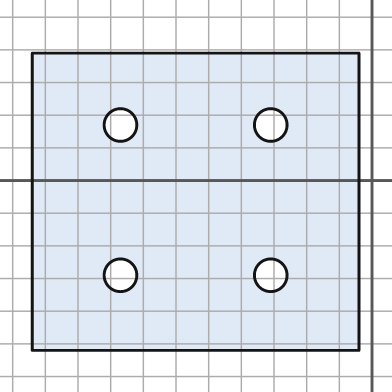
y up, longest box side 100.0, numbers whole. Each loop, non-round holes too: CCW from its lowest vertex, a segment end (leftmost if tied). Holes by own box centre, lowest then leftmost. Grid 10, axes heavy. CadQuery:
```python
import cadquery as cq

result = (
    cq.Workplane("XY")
    .moveTo(-104.0, -52.0)
    .lineTo(-4.0, -52.0)
    .lineTo(-4.0, 39.0)
    .lineTo(-104.0, 39.0)
    .close()
    .moveTo(-77.0, -29.0)
    .circle(5.0)
    .moveTo(-31.0, -29.0)
    .circle(5.0)
    .moveTo(-77.0, 17.0)
    .circle(5.0)
    .moveTo(-31.0, 17.0)
    .circle(5.0)
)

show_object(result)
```